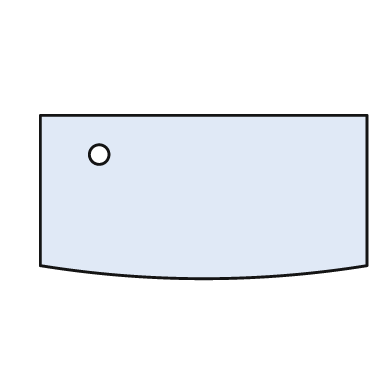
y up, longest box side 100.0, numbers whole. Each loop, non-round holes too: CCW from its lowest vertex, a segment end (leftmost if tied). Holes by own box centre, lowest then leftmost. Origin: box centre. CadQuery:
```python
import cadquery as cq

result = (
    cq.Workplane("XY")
    .moveTo(-50.0, -21.0)
    .threePointArc((0.0, -25.0), (50.0, -21.0))
    .lineTo(50.0, 25.0)
    .lineTo(-50.0, 25.0)
    .close()
    .moveTo(-32.0, 13.0)
    .circle(3.0)
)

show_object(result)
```